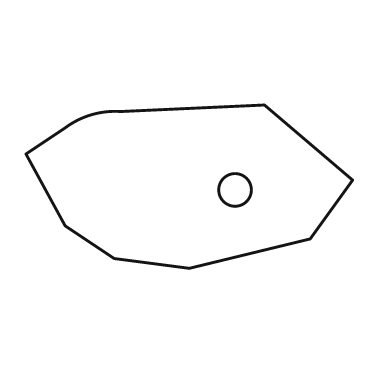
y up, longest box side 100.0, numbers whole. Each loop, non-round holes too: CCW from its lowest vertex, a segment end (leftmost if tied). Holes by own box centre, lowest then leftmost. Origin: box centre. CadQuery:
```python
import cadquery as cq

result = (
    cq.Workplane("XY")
    .moveTo(0.0, -25.0)
    .lineTo(37.0, -16.0)
    .lineTo(50.0, 2.0)
    .lineTo(23.0, 25.0)
    .lineTo(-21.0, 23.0)
    .threePointArc((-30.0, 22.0), (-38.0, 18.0))
    .lineTo(-50.0, 10.0)
    .lineTo(-38.0, -12.0)
    .lineTo(-23.0, -22.0)
    .close()
    .moveTo(14.0, -1.0)
    .circle(5.0)
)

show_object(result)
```